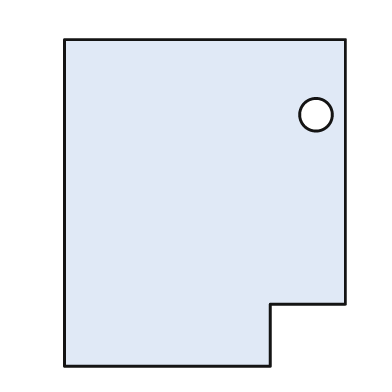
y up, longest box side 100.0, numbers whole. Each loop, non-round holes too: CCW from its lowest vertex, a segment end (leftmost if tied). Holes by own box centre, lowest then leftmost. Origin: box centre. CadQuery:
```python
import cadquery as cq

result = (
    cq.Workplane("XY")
    .moveTo(-43.0, -50.0)
    .lineTo(20.0, -50.0)
    .lineTo(20.0, -31.0)
    .lineTo(43.0, -31.0)
    .lineTo(43.0, 50.0)
    .lineTo(-43.0, 50.0)
    .close()
    .moveTo(34.0, 27.0)
    .circle(5.0)
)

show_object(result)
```